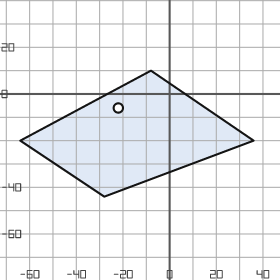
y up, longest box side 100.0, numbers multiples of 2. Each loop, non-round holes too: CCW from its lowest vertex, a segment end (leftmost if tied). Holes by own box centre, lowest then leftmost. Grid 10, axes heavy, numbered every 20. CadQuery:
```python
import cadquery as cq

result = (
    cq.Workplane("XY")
    .moveTo(-28.0, -44.0)
    .lineTo(36.0, -20.0)
    .lineTo(-8.0, 10.0)
    .lineTo(-64.0, -20.0)
    .close()
    .moveTo(-22.0, -6.0)
    .circle(2.0)
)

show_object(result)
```